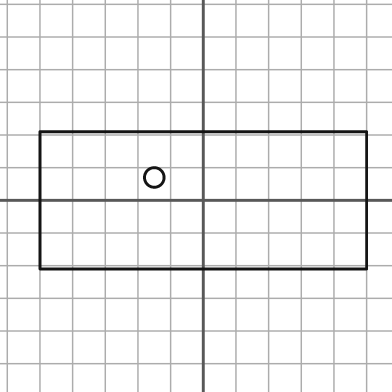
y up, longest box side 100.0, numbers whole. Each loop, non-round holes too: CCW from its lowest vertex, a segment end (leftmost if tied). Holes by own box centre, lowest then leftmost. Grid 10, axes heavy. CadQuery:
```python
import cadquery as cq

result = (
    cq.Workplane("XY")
    .moveTo(-50.0, -21.0)
    .lineTo(50.0, -21.0)
    .lineTo(50.0, 21.0)
    .lineTo(-50.0, 21.0)
    .close()
    .moveTo(-15.0, 7.0)
    .circle(3.0)
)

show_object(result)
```